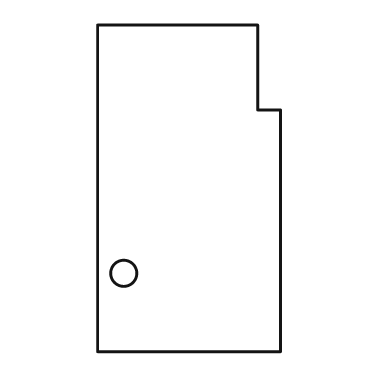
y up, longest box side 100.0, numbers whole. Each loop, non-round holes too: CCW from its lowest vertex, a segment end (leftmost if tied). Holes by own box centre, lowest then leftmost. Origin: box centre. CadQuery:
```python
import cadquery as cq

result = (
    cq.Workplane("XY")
    .moveTo(-28.0, -50.0)
    .lineTo(28.0, -50.0)
    .lineTo(28.0, 24.0)
    .lineTo(21.0, 24.0)
    .lineTo(21.0, 50.0)
    .lineTo(-28.0, 50.0)
    .close()
    .moveTo(-20.0, -26.0)
    .circle(4.0)
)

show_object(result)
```